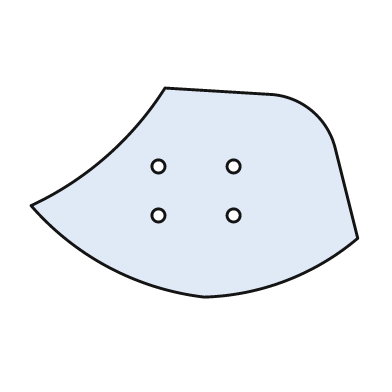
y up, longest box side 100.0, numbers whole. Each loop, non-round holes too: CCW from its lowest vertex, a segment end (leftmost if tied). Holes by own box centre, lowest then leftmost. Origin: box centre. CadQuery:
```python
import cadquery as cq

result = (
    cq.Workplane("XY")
    .moveTo(3.0, -32.0)
    .threePointArc((28.0, -27.0), (50.0, -14.0))
    .lineTo(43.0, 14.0)
    .threePointArc((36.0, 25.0), (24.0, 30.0))
    .lineTo(-9.0, 32.0)
    .threePointArc((-27.0, 11.0), (-50.0, -4.0))
    .threePointArc((-26.0, -23.0), (3.0, -32.0))
    .close()
    .moveTo(-11.0, -7.0)
    .circle(2.0)
    .moveTo(12.0, -7.0)
    .circle(2.0)
    .moveTo(-11.0, 8.0)
    .circle(2.0)
    .moveTo(12.0, 8.0)
    .circle(2.0)
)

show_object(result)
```